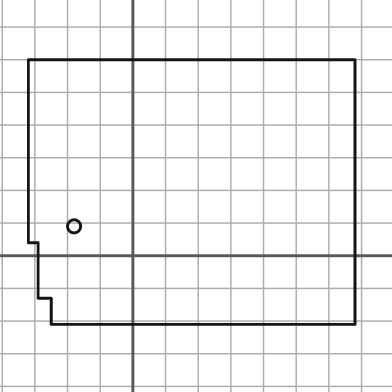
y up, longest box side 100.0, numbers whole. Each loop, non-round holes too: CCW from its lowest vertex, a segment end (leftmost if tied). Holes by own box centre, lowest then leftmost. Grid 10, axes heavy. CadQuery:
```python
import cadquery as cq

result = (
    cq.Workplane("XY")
    .moveTo(-25.0, -21.0)
    .lineTo(68.0, -21.0)
    .lineTo(68.0, 60.0)
    .lineTo(-32.0, 60.0)
    .lineTo(-32.0, 4.0)
    .lineTo(-29.0, 4.0)
    .lineTo(-29.0, -13.0)
    .lineTo(-25.0, -13.0)
    .close()
    .moveTo(-18.0, 9.0)
    .circle(2.0)
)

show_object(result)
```